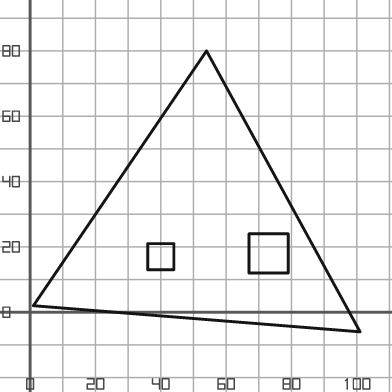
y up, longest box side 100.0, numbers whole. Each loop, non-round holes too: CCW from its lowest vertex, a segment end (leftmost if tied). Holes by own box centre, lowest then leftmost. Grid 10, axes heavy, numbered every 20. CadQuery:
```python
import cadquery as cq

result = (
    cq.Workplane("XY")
    .moveTo(101.0, -6.0)
    .lineTo(54.0, 80.0)
    .lineTo(1.0, 2.0)
    .close()
    .moveTo(36.0, 13.0)
    .lineTo(44.0, 13.0)
    .lineTo(44.0, 21.0)
    .lineTo(36.0, 21.0)
    .close()
    .moveTo(67.0, 12.0)
    .lineTo(79.0, 12.0)
    .lineTo(79.0, 24.0)
    .lineTo(67.0, 24.0)
    .close()
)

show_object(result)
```